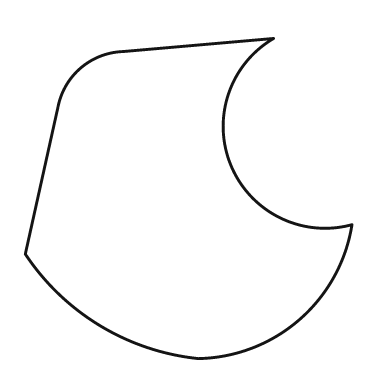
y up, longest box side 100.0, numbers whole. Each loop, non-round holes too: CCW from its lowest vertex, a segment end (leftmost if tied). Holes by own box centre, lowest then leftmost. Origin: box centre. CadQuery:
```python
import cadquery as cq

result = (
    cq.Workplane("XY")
    .moveTo(3.0, -49.0)
    .threePointArc((34.0, -37.0), (50.0, -8.0))
    .threePointArc((13.0, 10.0), (26.0, 49.0))
    .lineTo(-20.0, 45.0)
    .threePointArc((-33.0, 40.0), (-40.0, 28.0))
    .lineTo(-50.0, -17.0)
    .threePointArc((-27.0, -39.0), (3.0, -49.0))
    .close()
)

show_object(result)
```